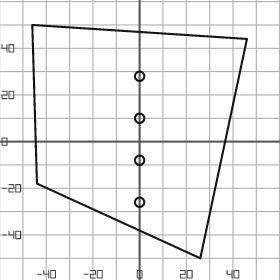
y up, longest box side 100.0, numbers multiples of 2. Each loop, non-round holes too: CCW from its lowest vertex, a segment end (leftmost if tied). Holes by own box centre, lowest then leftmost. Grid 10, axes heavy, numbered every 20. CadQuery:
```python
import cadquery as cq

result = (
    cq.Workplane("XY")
    .moveTo(26.0, -50.0)
    .lineTo(46.0, 44.0)
    .lineTo(-46.0, 50.0)
    .lineTo(-44.0, -18.0)
    .close()
    .moveTo(0.0, -26.0)
    .circle(2.0)
    .moveTo(0.0, -8.0)
    .circle(2.0)
    .moveTo(0.0, 10.0)
    .circle(2.0)
    .moveTo(0.0, 28.0)
    .circle(2.0)
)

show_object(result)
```